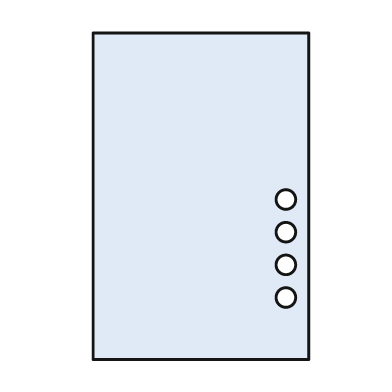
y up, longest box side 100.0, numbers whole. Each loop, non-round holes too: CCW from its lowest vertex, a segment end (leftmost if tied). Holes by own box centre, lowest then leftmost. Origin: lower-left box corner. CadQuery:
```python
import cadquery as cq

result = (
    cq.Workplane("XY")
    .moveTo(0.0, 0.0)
    .lineTo(66.0, 0.0)
    .lineTo(66.0, 100.0)
    .lineTo(0.0, 100.0)
    .close()
    .moveTo(59.0, 19.0)
    .circle(3.0)
    .moveTo(59.0, 29.0)
    .circle(3.0)
    .moveTo(59.0, 39.0)
    .circle(3.0)
    .moveTo(59.0, 49.0)
    .circle(3.0)
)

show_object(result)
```